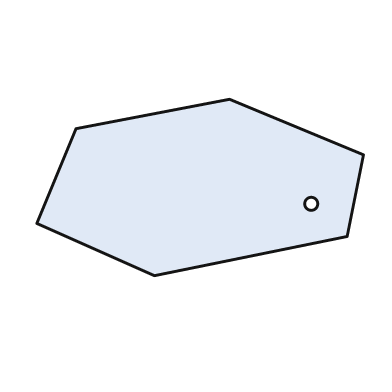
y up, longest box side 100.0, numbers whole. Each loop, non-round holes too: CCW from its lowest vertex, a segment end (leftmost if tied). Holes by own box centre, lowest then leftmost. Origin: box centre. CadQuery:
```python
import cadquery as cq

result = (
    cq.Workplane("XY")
    .moveTo(-14.0, -27.0)
    .lineTo(45.0, -15.0)
    .lineTo(50.0, 10.0)
    .lineTo(9.0, 27.0)
    .lineTo(-38.0, 18.0)
    .lineTo(-50.0, -11.0)
    .close()
    .moveTo(34.0, -5.0)
    .circle(2.0)
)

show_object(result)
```